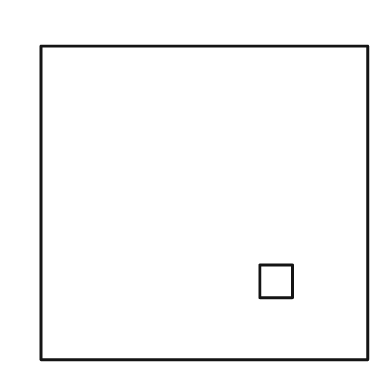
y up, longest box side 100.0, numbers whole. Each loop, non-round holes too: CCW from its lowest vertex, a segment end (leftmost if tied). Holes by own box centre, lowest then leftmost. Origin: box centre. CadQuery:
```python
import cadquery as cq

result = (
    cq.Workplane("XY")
    .moveTo(-50.0, -48.0)
    .lineTo(50.0, -48.0)
    .lineTo(50.0, 48.0)
    .lineTo(-50.0, 48.0)
    .close()
    .moveTo(17.0, -29.0)
    .lineTo(27.0, -29.0)
    .lineTo(27.0, -19.0)
    .lineTo(17.0, -19.0)
    .close()
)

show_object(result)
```